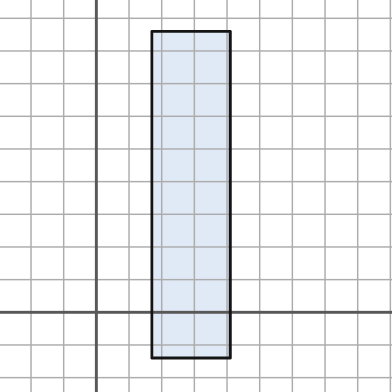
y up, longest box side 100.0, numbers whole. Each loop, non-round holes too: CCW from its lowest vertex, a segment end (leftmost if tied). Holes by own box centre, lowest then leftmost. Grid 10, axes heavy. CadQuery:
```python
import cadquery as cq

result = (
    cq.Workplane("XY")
    .moveTo(17.0, -14.0)
    .lineTo(41.0, -14.0)
    .lineTo(41.0, 86.0)
    .lineTo(17.0, 86.0)
    .close()
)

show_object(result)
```